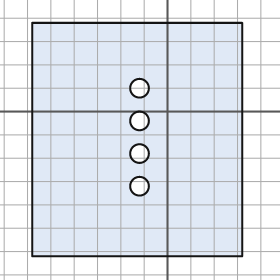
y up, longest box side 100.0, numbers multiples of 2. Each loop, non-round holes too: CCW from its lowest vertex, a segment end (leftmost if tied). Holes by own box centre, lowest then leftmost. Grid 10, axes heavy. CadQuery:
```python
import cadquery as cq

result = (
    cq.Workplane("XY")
    .moveTo(-58.0, -62.0)
    .lineTo(32.0, -62.0)
    .lineTo(32.0, 38.0)
    .lineTo(-58.0, 38.0)
    .close()
    .moveTo(-12.0, -32.0)
    .circle(4.0)
    .moveTo(-12.0, -18.0)
    .circle(4.0)
    .moveTo(-12.0, -4.0)
    .circle(4.0)
    .moveTo(-12.0, 10.0)
    .circle(4.0)
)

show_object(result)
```